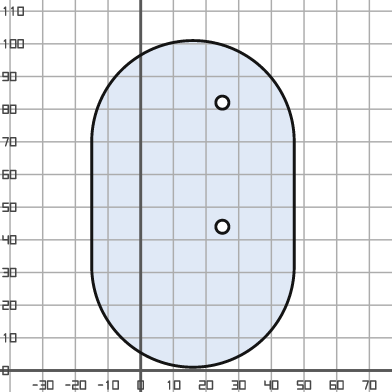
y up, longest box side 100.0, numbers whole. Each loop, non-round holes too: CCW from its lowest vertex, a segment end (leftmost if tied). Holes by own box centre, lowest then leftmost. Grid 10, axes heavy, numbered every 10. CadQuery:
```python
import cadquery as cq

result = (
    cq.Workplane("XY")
    .moveTo(-15.0, 32.0)
    .threePointArc((16.0, 1.0), (47.0, 32.0))
    .lineTo(47.0, 70.0)
    .threePointArc((16.0, 101.0), (-15.0, 70.0))
    .close()
    .moveTo(25.0, 44.0)
    .circle(2.0)
    .moveTo(25.0, 82.0)
    .circle(2.0)
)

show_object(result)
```